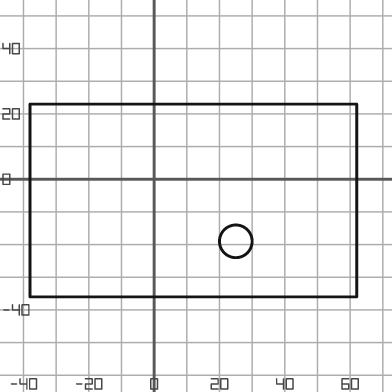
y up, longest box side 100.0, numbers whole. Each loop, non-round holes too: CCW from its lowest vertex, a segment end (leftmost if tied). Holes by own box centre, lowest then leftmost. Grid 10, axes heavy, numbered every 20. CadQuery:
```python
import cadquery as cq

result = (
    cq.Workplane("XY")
    .moveTo(-38.0, -36.0)
    .lineTo(62.0, -36.0)
    .lineTo(62.0, 23.0)
    .lineTo(-38.0, 23.0)
    .close()
    .moveTo(25.0, -19.0)
    .circle(5.0)
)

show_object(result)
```